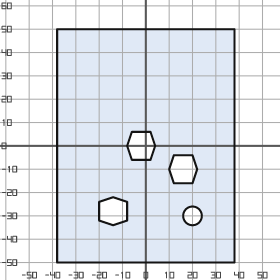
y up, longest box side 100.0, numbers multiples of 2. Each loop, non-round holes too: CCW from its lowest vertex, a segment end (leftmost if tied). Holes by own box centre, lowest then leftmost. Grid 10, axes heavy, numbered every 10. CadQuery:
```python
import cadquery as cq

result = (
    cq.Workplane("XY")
    .moveTo(-38.0, -50.0)
    .lineTo(38.0, -50.0)
    .lineTo(38.0, 50.0)
    .lineTo(-38.0, 50.0)
    .close()
    .moveTo(20.0, -30.0)
    .circle(4.0)
    .moveTo(-14.0, -34.0)
    .lineTo(-8.0, -32.0)
    .lineTo(-8.0, -24.0)
    .lineTo(-14.0, -22.0)
    .lineTo(-20.0, -24.0)
    .lineTo(-20.0, -32.0)
    .close()
    .moveTo(12.0, -16.0)
    .lineTo(20.0, -16.0)
    .lineTo(22.0, -10.0)
    .lineTo(20.0, -4.0)
    .lineTo(12.0, -4.0)
    .lineTo(10.0, -10.0)
    .close()
    .moveTo(-6.0, -6.0)
    .lineTo(2.0, -6.0)
    .lineTo(4.0, 0.0)
    .lineTo(2.0, 6.0)
    .lineTo(-6.0, 6.0)
    .lineTo(-8.0, 0.0)
    .close()
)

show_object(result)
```